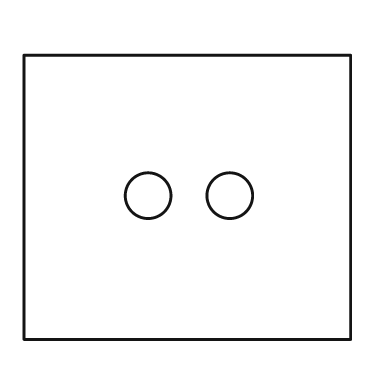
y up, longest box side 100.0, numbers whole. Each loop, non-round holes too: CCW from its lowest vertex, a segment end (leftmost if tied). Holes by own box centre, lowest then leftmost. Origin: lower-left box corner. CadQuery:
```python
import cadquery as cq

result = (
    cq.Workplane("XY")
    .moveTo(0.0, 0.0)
    .lineTo(100.0, 0.0)
    .lineTo(100.0, 87.0)
    .lineTo(0.0, 87.0)
    .close()
    .moveTo(38.0, 44.0)
    .circle(7.0)
    .moveTo(63.0, 44.0)
    .circle(7.0)
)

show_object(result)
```